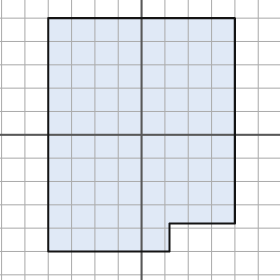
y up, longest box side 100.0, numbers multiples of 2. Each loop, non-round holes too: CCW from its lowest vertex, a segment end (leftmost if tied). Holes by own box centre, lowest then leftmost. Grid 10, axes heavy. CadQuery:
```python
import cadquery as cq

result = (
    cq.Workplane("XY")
    .moveTo(-40.0, -50.0)
    .lineTo(12.0, -50.0)
    .lineTo(12.0, -38.0)
    .lineTo(40.0, -38.0)
    .lineTo(40.0, 50.0)
    .lineTo(-40.0, 50.0)
    .close()
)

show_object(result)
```